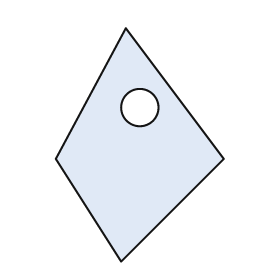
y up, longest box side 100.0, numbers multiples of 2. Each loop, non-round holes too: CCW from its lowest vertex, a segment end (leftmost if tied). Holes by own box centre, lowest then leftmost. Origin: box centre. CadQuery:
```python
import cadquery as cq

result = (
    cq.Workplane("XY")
    .moveTo(-8.0, -50.0)
    .lineTo(36.0, -6.0)
    .lineTo(-6.0, 50.0)
    .lineTo(-36.0, -6.0)
    .close()
    .moveTo(0.0, 16.0)
    .circle(8.0)
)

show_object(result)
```